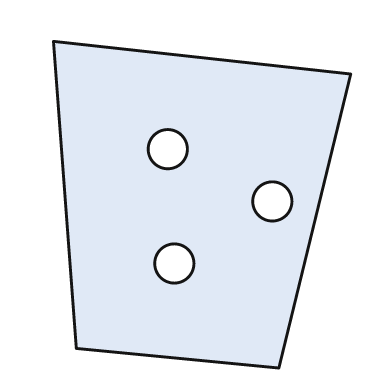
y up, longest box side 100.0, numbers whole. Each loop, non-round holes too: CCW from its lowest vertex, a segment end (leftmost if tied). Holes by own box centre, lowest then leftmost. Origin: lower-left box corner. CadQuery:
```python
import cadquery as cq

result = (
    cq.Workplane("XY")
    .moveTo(69.0, 0.0)
    .lineTo(91.0, 90.0)
    .lineTo(0.0, 100.0)
    .lineTo(7.0, 6.0)
    .close()
    .moveTo(37.0, 32.0)
    .circle(6.0)
    .moveTo(67.0, 51.0)
    .circle(6.0)
    .moveTo(35.0, 67.0)
    .circle(6.0)
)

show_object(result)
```